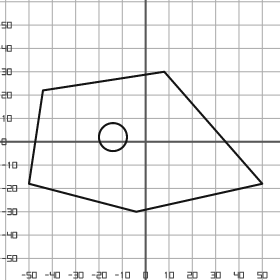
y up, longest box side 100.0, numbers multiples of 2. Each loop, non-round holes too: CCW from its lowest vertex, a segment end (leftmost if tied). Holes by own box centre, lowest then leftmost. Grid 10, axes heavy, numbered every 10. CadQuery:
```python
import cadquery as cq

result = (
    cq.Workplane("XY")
    .moveTo(-4.0, -30.0)
    .lineTo(50.0, -18.0)
    .lineTo(8.0, 30.0)
    .lineTo(-44.0, 22.0)
    .lineTo(-50.0, -18.0)
    .close()
    .moveTo(-14.0, 2.0)
    .circle(6.0)
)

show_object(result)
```